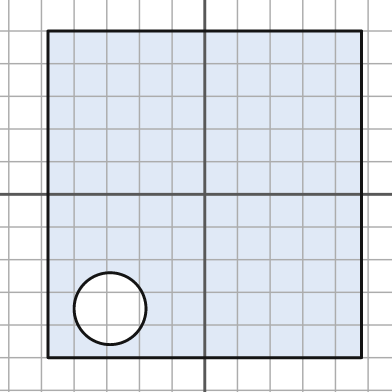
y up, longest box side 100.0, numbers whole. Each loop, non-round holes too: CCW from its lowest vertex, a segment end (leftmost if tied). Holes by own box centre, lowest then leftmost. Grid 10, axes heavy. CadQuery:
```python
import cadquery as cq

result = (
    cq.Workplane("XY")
    .moveTo(-48.0, -50.0)
    .lineTo(48.0, -50.0)
    .lineTo(48.0, 50.0)
    .lineTo(-48.0, 50.0)
    .close()
    .moveTo(-29.0, -35.0)
    .circle(11.0)
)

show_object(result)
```